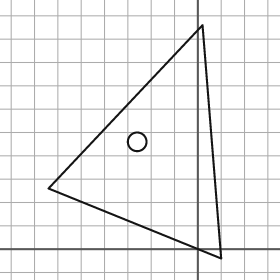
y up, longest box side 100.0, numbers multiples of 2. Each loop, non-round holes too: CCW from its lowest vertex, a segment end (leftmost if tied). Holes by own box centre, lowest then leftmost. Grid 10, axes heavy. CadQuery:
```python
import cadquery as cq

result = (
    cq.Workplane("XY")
    .moveTo(10.0, -4.0)
    .lineTo(2.0, 96.0)
    .lineTo(-64.0, 26.0)
    .close()
    .moveTo(-26.0, 46.0)
    .circle(4.0)
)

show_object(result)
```